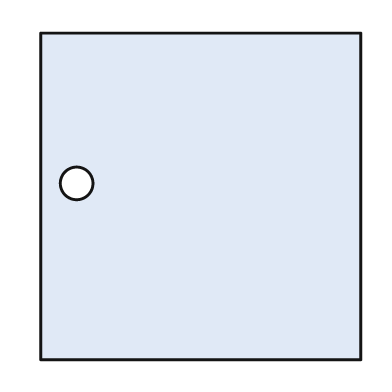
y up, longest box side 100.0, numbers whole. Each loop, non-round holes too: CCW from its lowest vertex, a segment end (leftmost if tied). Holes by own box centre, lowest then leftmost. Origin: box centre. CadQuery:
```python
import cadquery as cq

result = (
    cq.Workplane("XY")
    .moveTo(-49.0, -50.0)
    .lineTo(49.0, -50.0)
    .lineTo(49.0, 50.0)
    .lineTo(-49.0, 50.0)
    .close()
    .moveTo(-38.0, 4.0)
    .circle(5.0)
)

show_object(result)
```